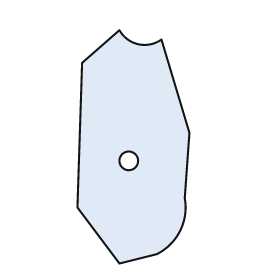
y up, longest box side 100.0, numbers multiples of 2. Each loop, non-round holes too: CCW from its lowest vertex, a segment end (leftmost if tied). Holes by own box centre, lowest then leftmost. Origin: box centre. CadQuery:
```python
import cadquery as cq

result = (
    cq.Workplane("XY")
    .moveTo(-6.0, -50.0)
    .lineTo(10.0, -46.0)
    .threePointArc((20.0, -36.0), (22.0, -22.0))
    .lineTo(24.0, 6.0)
    .lineTo(12.0, 46.0)
    .threePointArc((2.0, 44.0), (-6.0, 50.0))
    .lineTo(-22.0, 36.0)
    .lineTo(-24.0, -26.0)
    .close()
    .moveTo(-2.0, -6.0)
    .circle(4.0)
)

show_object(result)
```